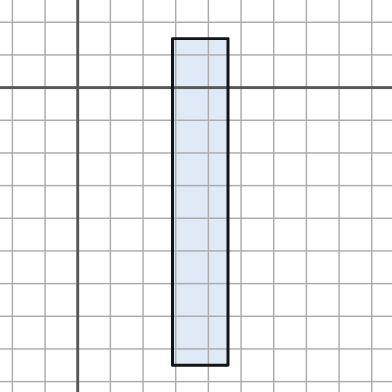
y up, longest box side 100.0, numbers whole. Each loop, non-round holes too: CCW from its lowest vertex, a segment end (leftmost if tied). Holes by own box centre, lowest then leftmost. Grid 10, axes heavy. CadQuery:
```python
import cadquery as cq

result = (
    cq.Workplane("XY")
    .moveTo(29.0, -85.0)
    .lineTo(46.0, -85.0)
    .lineTo(46.0, 15.0)
    .lineTo(29.0, 15.0)
    .close()
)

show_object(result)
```